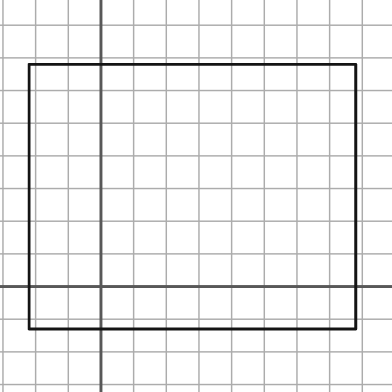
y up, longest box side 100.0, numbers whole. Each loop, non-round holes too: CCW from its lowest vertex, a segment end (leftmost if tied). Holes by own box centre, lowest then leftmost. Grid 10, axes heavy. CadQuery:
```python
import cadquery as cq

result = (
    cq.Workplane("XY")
    .moveTo(-22.0, -13.0)
    .lineTo(78.0, -13.0)
    .lineTo(78.0, 68.0)
    .lineTo(-22.0, 68.0)
    .close()
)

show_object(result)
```